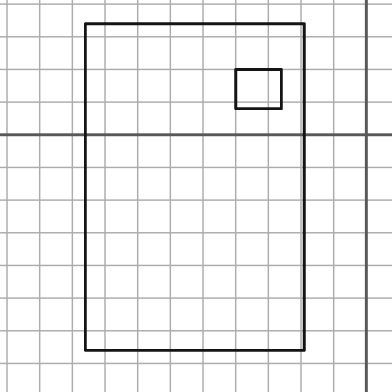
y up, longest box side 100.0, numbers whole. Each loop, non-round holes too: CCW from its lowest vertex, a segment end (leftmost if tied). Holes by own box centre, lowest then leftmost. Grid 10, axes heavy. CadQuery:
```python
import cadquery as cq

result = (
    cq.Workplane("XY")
    .moveTo(-86.0, -66.0)
    .lineTo(-19.0, -66.0)
    .lineTo(-19.0, 34.0)
    .lineTo(-86.0, 34.0)
    .close()
    .moveTo(-40.0, 8.0)
    .lineTo(-26.0, 8.0)
    .lineTo(-26.0, 20.0)
    .lineTo(-40.0, 20.0)
    .close()
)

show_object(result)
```